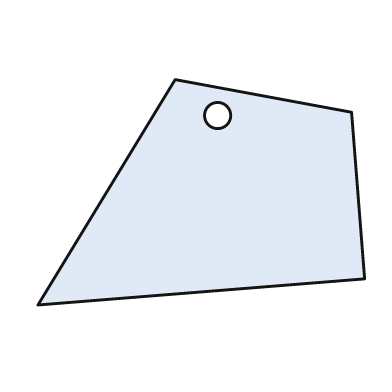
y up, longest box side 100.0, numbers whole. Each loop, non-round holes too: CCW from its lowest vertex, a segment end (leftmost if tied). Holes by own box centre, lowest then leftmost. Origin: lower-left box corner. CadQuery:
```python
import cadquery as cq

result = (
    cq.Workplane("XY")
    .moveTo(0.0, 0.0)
    .lineTo(100.0, 8.0)
    .lineTo(96.0, 59.0)
    .lineTo(42.0, 69.0)
    .close()
    .moveTo(55.0, 58.0)
    .circle(4.0)
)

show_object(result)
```